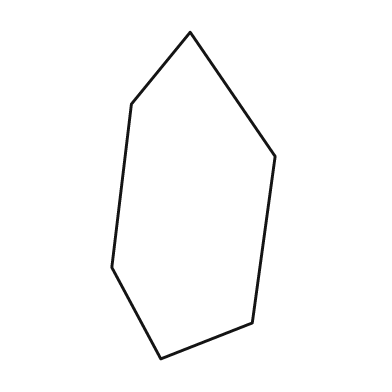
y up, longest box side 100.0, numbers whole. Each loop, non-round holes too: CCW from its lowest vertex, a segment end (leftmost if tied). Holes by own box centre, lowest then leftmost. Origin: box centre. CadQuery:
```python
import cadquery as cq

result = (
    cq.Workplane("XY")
    .moveTo(-10.0, -50.0)
    .lineTo(18.0, -39.0)
    .lineTo(25.0, 12.0)
    .lineTo(-1.0, 50.0)
    .lineTo(-19.0, 28.0)
    .lineTo(-25.0, -22.0)
    .close()
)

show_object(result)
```